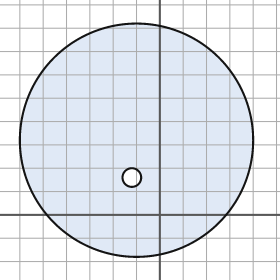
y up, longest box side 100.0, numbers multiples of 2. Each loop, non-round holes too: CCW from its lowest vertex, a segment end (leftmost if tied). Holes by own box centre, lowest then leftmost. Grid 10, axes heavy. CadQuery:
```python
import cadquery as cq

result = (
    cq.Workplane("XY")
    .moveTo(-10.0, 32.0)
    .circle(50.0)
    .moveTo(-12.0, 16.0)
    .circle(4.0)
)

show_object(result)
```